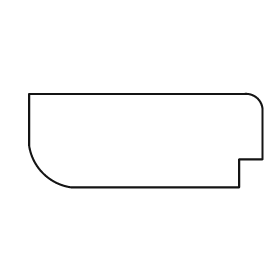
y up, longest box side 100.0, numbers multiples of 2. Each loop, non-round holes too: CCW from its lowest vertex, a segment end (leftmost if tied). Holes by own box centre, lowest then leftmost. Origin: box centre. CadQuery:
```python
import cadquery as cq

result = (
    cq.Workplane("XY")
    .moveTo(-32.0, -20.0)
    .lineTo(40.0, -20.0)
    .lineTo(40.0, -8.0)
    .lineTo(50.0, -8.0)
    .lineTo(50.0, 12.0)
    .threePointArc((48.0, 18.0), (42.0, 20.0))
    .lineTo(-50.0, 20.0)
    .lineTo(-50.0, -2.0)
    .threePointArc((-44.0, -14.0), (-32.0, -20.0))
    .close()
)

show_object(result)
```